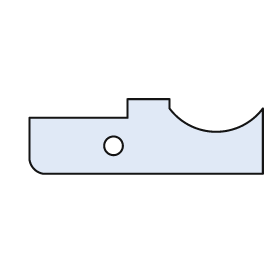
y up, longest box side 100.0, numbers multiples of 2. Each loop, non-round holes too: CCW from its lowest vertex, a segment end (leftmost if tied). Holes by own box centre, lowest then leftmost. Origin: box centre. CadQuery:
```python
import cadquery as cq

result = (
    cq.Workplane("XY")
    .moveTo(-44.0, -16.0)
    .lineTo(50.0, -16.0)
    .lineTo(50.0, 12.0)
    .threePointArc((30.0, 2.0), (10.0, 12.0))
    .lineTo(10.0, 16.0)
    .lineTo(-8.0, 16.0)
    .lineTo(-8.0, 8.0)
    .lineTo(-50.0, 8.0)
    .lineTo(-50.0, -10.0)
    .threePointArc((-48.0, -14.0), (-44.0, -16.0))
    .close()
    .moveTo(-14.0, -4.0)
    .circle(4.0)
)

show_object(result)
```